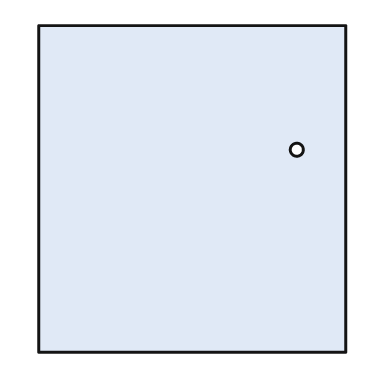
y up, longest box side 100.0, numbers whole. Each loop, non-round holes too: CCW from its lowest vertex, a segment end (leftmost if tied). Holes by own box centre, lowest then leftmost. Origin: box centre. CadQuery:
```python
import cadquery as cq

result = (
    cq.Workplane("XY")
    .moveTo(-47.0, -50.0)
    .lineTo(47.0, -50.0)
    .lineTo(47.0, 50.0)
    .lineTo(-47.0, 50.0)
    .close()
    .moveTo(32.0, 12.0)
    .circle(2.0)
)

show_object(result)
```